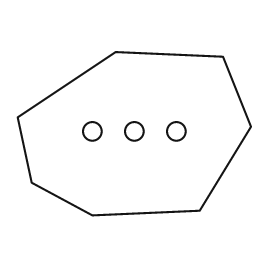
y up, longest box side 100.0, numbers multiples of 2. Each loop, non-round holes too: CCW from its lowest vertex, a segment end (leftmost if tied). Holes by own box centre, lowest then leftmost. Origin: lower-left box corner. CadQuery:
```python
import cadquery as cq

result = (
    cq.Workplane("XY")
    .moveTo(32.0, 0.0)
    .lineTo(78.0, 2.0)
    .lineTo(100.0, 38.0)
    .lineTo(88.0, 68.0)
    .lineTo(42.0, 70.0)
    .lineTo(0.0, 42.0)
    .lineTo(6.0, 14.0)
    .close()
    .moveTo(32.0, 36.0)
    .circle(4.0)
    .moveTo(50.0, 36.0)
    .circle(4.0)
    .moveTo(68.0, 36.0)
    .circle(4.0)
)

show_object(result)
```